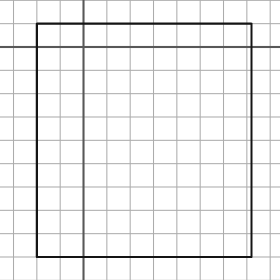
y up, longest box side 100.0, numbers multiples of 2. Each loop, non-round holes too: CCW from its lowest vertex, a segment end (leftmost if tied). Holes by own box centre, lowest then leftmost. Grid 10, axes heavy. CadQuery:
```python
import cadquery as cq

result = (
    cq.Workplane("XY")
    .moveTo(-20.0, -90.0)
    .lineTo(72.0, -90.0)
    .lineTo(72.0, 10.0)
    .lineTo(-20.0, 10.0)
    .close()
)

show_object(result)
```